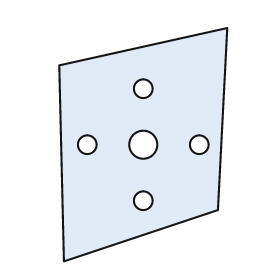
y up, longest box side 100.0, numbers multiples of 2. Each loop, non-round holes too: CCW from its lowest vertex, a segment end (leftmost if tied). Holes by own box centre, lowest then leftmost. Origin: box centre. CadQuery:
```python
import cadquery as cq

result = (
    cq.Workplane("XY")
    .moveTo(-34.0, -50.0)
    .lineTo(32.0, -28.0)
    .lineTo(36.0, 50.0)
    .lineTo(-36.0, 34.0)
    .close()
    .moveTo(0.0, -24.0)
    .circle(4.0)
    .moveTo(-24.0, 0.0)
    .circle(4.0)
    .moveTo(0.0, 0.0)
    .circle(6.0)
    .moveTo(24.0, 0.0)
    .circle(4.0)
    .moveTo(0.0, 24.0)
    .circle(4.0)
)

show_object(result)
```